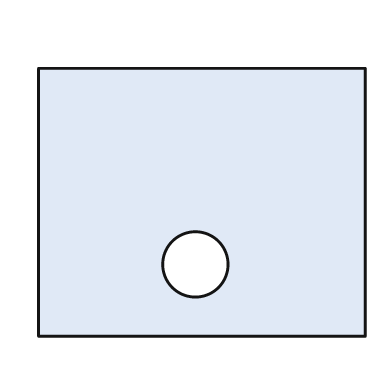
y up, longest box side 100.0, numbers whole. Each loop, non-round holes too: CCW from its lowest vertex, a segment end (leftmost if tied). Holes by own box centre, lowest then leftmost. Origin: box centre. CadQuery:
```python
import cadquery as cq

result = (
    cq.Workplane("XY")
    .moveTo(-50.0, -41.0)
    .lineTo(50.0, -41.0)
    .lineTo(50.0, 41.0)
    .lineTo(-50.0, 41.0)
    .close()
    .moveTo(-2.0, -19.0)
    .circle(10.0)
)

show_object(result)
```